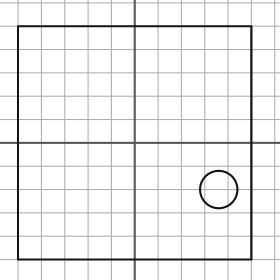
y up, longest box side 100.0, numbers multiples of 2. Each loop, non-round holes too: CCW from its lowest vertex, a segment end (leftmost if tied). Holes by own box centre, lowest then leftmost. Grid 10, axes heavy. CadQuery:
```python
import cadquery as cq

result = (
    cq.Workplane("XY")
    .moveTo(-50.0, -50.0)
    .lineTo(50.0, -50.0)
    .lineTo(50.0, 50.0)
    .lineTo(-50.0, 50.0)
    .close()
    .moveTo(36.0, -20.0)
    .circle(8.0)
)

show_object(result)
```